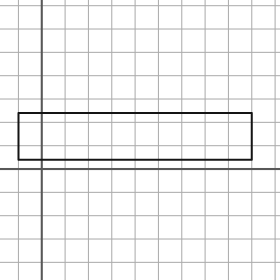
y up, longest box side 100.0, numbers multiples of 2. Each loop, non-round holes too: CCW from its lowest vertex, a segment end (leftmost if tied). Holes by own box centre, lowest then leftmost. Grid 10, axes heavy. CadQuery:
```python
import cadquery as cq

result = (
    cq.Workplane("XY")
    .moveTo(-10.0, 4.0)
    .lineTo(90.0, 4.0)
    .lineTo(90.0, 24.0)
    .lineTo(-10.0, 24.0)
    .close()
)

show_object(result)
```